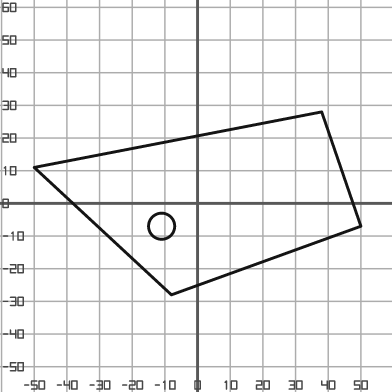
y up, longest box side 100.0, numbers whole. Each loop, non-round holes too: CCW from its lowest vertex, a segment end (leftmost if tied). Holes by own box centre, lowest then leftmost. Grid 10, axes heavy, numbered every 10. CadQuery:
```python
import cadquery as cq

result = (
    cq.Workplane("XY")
    .moveTo(-8.0, -28.0)
    .lineTo(50.0, -7.0)
    .lineTo(38.0, 28.0)
    .lineTo(-50.0, 11.0)
    .close()
    .moveTo(-11.0, -7.0)
    .circle(4.0)
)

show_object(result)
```